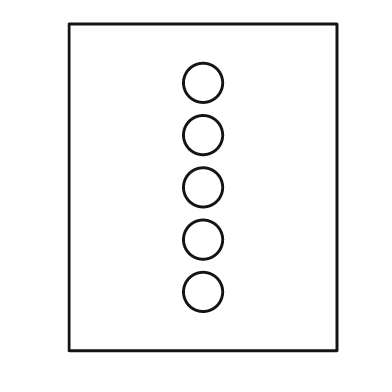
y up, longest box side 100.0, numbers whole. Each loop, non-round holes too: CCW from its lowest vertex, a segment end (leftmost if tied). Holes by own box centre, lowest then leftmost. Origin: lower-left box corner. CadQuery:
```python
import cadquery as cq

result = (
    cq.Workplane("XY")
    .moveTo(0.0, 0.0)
    .lineTo(82.0, 0.0)
    .lineTo(82.0, 100.0)
    .lineTo(0.0, 100.0)
    .close()
    .moveTo(41.0, 18.0)
    .circle(6.0)
    .moveTo(41.0, 34.0)
    .circle(6.0)
    .moveTo(41.0, 50.0)
    .circle(6.0)
    .moveTo(41.0, 66.0)
    .circle(6.0)
    .moveTo(41.0, 82.0)
    .circle(6.0)
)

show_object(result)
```